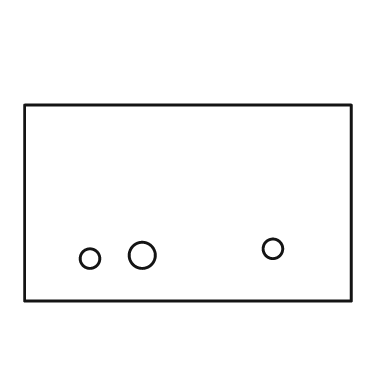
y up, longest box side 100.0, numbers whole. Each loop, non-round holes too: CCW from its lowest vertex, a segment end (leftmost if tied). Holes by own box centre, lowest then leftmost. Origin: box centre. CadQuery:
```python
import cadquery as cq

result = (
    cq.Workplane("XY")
    .moveTo(-50.0, -30.0)
    .lineTo(50.0, -30.0)
    .lineTo(50.0, 30.0)
    .lineTo(-50.0, 30.0)
    .close()
    .moveTo(-30.0, -17.0)
    .circle(3.0)
    .moveTo(-14.0, -16.0)
    .circle(4.0)
    .moveTo(26.0, -14.0)
    .circle(3.0)
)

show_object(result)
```